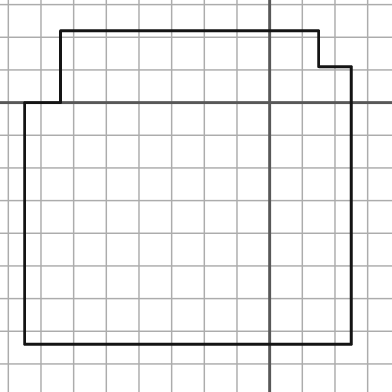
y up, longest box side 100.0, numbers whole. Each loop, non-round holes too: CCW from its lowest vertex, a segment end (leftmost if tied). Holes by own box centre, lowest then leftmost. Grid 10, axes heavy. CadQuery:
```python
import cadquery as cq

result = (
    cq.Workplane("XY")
    .moveTo(-75.0, -74.0)
    .lineTo(25.0, -74.0)
    .lineTo(25.0, 11.0)
    .lineTo(15.0, 11.0)
    .lineTo(15.0, 22.0)
    .lineTo(-64.0, 22.0)
    .lineTo(-64.0, 0.0)
    .lineTo(-75.0, 0.0)
    .close()
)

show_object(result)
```